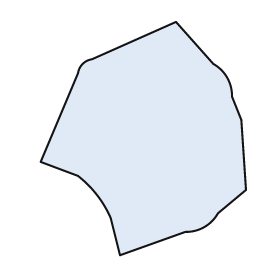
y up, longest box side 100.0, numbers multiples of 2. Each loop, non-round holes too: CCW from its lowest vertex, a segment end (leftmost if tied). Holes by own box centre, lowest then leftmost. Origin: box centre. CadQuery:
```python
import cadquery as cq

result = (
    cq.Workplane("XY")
    .moveTo(-10.0, -50.0)
    .lineTo(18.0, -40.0)
    .threePointArc((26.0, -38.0), (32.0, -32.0))
    .lineTo(44.0, -22.0)
    .lineTo(42.0, 8.0)
    .lineTo(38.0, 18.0)
    .threePointArc((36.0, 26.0), (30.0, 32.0))
    .lineTo(14.0, 50.0)
    .lineTo(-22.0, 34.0)
    .threePointArc((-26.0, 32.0), (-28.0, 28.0))
    .lineTo(-44.0, -10.0)
    .lineTo(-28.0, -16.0)
    .threePointArc((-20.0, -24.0), (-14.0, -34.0))
    .close()
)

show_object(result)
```